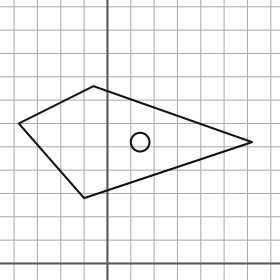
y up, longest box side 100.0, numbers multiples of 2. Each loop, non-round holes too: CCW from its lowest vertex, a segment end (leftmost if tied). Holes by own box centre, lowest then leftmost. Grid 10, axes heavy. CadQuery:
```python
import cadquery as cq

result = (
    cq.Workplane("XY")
    .moveTo(-10.0, 28.0)
    .lineTo(62.0, 52.0)
    .lineTo(-6.0, 76.0)
    .lineTo(-38.0, 60.0)
    .close()
    .moveTo(14.0, 52.0)
    .circle(4.0)
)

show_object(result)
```